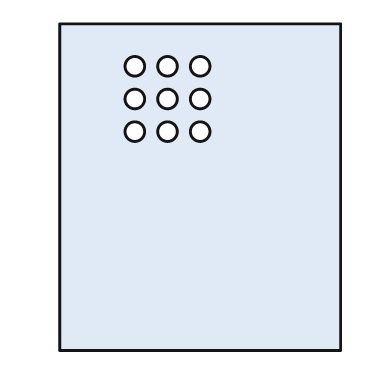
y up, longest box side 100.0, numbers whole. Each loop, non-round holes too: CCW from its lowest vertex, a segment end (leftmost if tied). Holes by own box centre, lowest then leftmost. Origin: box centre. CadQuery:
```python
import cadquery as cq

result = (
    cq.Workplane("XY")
    .moveTo(-43.0, -50.0)
    .lineTo(43.0, -50.0)
    .lineTo(43.0, 50.0)
    .lineTo(-43.0, 50.0)
    .close()
    .moveTo(-20.0, 17.0)
    .circle(3.0)
    .moveTo(-10.0, 17.0)
    .circle(3.0)
    .moveTo(0.0, 17.0)
    .circle(3.0)
    .moveTo(-20.0, 27.0)
    .circle(3.0)
    .moveTo(-10.0, 27.0)
    .circle(3.0)
    .moveTo(0.0, 27.0)
    .circle(3.0)
    .moveTo(-20.0, 37.0)
    .circle(3.0)
    .moveTo(-10.0, 37.0)
    .circle(3.0)
    .moveTo(0.0, 37.0)
    .circle(3.0)
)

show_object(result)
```